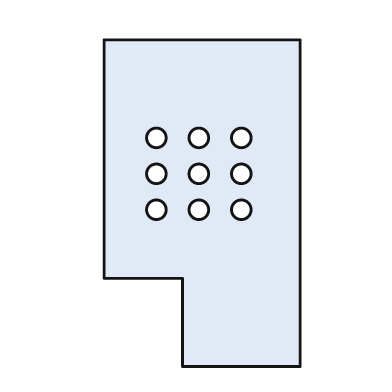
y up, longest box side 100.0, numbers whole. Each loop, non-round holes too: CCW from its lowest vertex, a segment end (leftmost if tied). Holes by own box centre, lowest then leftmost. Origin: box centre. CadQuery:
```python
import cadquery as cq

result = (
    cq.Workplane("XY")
    .moveTo(-6.0, -50.0)
    .lineTo(30.0, -50.0)
    .lineTo(30.0, 50.0)
    .lineTo(-30.0, 50.0)
    .lineTo(-30.0, -23.0)
    .lineTo(-6.0, -23.0)
    .close()
    .moveTo(-14.0, -2.0)
    .circle(3.0)
    .moveTo(-1.0, -2.0)
    .circle(3.0)
    .moveTo(12.0, -2.0)
    .circle(3.0)
    .moveTo(-14.0, 9.0)
    .circle(3.0)
    .moveTo(-1.0, 9.0)
    .circle(3.0)
    .moveTo(12.0, 9.0)
    .circle(3.0)
    .moveTo(-14.0, 20.0)
    .circle(3.0)
    .moveTo(-1.0, 20.0)
    .circle(3.0)
    .moveTo(12.0, 20.0)
    .circle(3.0)
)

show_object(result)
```